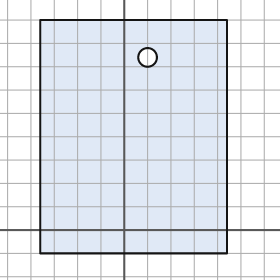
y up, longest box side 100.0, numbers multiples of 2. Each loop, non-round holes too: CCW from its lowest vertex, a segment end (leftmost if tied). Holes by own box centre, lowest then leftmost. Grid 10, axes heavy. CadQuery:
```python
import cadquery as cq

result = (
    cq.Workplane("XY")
    .moveTo(-36.0, -10.0)
    .lineTo(44.0, -10.0)
    .lineTo(44.0, 90.0)
    .lineTo(-36.0, 90.0)
    .close()
    .moveTo(10.0, 74.0)
    .circle(4.0)
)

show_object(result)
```